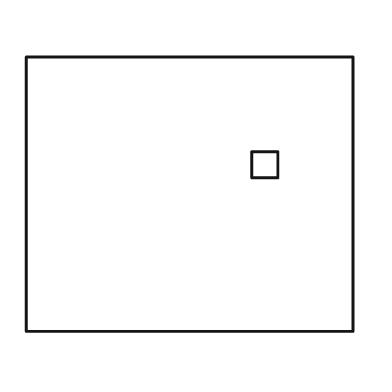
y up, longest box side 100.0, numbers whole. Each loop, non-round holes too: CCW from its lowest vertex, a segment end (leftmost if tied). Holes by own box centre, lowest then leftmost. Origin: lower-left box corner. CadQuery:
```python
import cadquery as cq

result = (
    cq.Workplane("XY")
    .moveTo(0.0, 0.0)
    .lineTo(100.0, 0.0)
    .lineTo(100.0, 84.0)
    .lineTo(0.0, 84.0)
    .close()
    .moveTo(69.0, 47.0)
    .lineTo(77.0, 47.0)
    .lineTo(77.0, 55.0)
    .lineTo(69.0, 55.0)
    .close()
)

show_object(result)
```